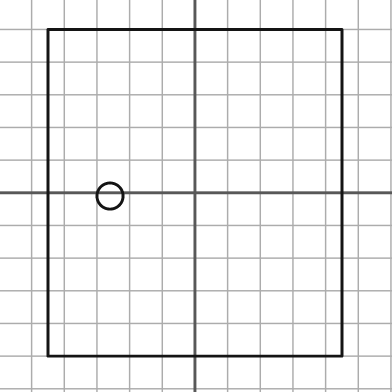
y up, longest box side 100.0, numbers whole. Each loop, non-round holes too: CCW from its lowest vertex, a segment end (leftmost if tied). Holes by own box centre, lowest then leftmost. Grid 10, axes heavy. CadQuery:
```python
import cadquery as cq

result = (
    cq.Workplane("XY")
    .moveTo(-45.0, -50.0)
    .lineTo(45.0, -50.0)
    .lineTo(45.0, 50.0)
    .lineTo(-45.0, 50.0)
    .close()
    .moveTo(-26.0, -1.0)
    .circle(4.0)
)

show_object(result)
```